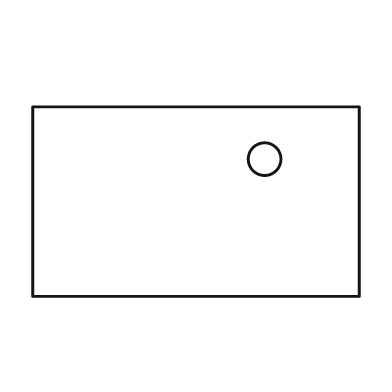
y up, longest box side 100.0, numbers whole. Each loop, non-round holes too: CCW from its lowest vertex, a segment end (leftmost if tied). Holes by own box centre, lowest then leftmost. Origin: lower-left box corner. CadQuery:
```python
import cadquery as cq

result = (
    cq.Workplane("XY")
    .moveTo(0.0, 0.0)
    .lineTo(100.0, 0.0)
    .lineTo(100.0, 58.0)
    .lineTo(0.0, 58.0)
    .close()
    .moveTo(71.0, 42.0)
    .circle(5.0)
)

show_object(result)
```